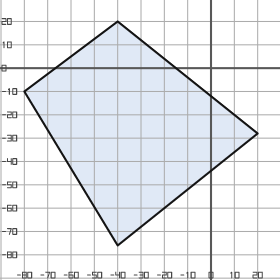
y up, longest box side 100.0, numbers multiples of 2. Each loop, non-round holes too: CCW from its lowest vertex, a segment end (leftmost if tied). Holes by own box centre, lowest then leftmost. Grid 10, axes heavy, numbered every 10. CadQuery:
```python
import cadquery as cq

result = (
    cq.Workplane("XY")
    .moveTo(-40.0, -76.0)
    .lineTo(20.0, -28.0)
    .lineTo(-40.0, 20.0)
    .lineTo(-80.0, -10.0)
    .close()
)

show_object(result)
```